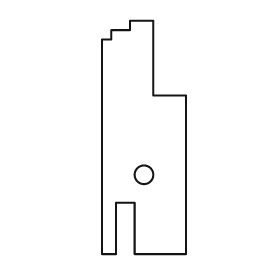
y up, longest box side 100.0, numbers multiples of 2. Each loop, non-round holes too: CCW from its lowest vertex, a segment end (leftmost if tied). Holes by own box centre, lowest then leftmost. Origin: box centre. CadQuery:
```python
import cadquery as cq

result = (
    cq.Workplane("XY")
    .moveTo(-18.0, -50.0)
    .lineTo(-12.0, -50.0)
    .lineTo(-12.0, -28.0)
    .lineTo(-4.0, -28.0)
    .lineTo(-4.0, -50.0)
    .lineTo(18.0, -50.0)
    .lineTo(18.0, 18.0)
    .lineTo(4.0, 18.0)
    .lineTo(4.0, 50.0)
    .lineTo(-6.0, 50.0)
    .lineTo(-6.0, 46.0)
    .lineTo(-14.0, 46.0)
    .lineTo(-14.0, 42.0)
    .lineTo(-18.0, 42.0)
    .close()
    .moveTo(0.0, -16.0)
    .circle(4.0)
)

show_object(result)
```